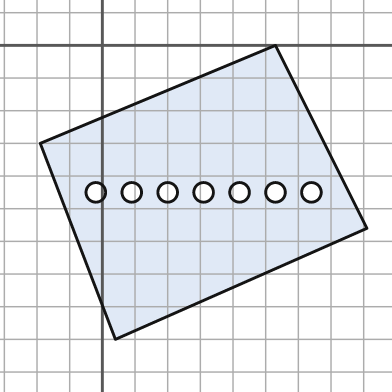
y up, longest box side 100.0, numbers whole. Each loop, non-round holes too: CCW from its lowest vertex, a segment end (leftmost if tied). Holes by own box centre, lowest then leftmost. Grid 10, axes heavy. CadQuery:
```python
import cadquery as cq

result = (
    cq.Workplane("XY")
    .moveTo(4.0, -90.0)
    .lineTo(81.0, -56.0)
    .lineTo(53.0, 0.0)
    .lineTo(-19.0, -30.0)
    .close()
    .moveTo(-2.0, -45.0)
    .circle(3.0)
    .moveTo(9.0, -45.0)
    .circle(3.0)
    .moveTo(20.0, -45.0)
    .circle(3.0)
    .moveTo(31.0, -45.0)
    .circle(3.0)
    .moveTo(42.0, -45.0)
    .circle(3.0)
    .moveTo(53.0, -45.0)
    .circle(3.0)
    .moveTo(64.0, -45.0)
    .circle(3.0)
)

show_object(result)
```